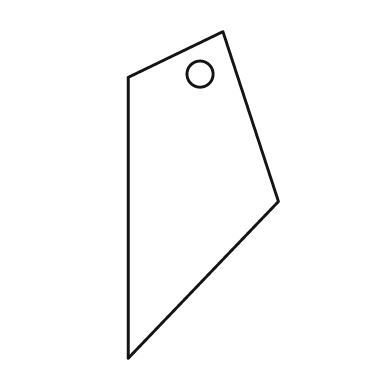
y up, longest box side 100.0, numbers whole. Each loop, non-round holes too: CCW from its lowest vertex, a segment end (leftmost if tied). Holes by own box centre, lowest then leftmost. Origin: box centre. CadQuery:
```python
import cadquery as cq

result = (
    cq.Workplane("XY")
    .moveTo(-23.0, -50.0)
    .lineTo(23.0, -2.0)
    .lineTo(6.0, 50.0)
    .lineTo(-23.0, 36.0)
    .close()
    .moveTo(-1.0, 37.0)
    .circle(4.0)
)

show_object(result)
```